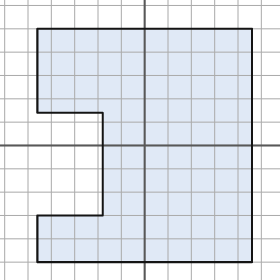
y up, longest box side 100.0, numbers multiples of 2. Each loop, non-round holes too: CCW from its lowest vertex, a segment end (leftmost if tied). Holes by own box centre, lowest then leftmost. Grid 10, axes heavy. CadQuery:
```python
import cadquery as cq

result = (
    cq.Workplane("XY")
    .moveTo(-46.0, -50.0)
    .lineTo(46.0, -50.0)
    .lineTo(46.0, 50.0)
    .lineTo(-46.0, 50.0)
    .lineTo(-46.0, 14.0)
    .lineTo(-18.0, 14.0)
    .lineTo(-18.0, -30.0)
    .lineTo(-46.0, -30.0)
    .close()
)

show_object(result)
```